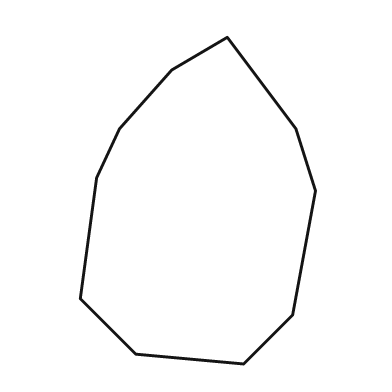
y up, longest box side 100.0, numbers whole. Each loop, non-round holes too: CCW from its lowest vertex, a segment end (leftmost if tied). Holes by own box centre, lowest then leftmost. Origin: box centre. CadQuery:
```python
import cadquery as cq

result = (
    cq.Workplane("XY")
    .moveTo(14.0, -50.0)
    .lineTo(29.0, -35.0)
    .lineTo(36.0, 3.0)
    .lineTo(30.0, 22.0)
    .lineTo(9.0, 50.0)
    .lineTo(-8.0, 40.0)
    .lineTo(-24.0, 22.0)
    .lineTo(-31.0, 7.0)
    .lineTo(-36.0, -30.0)
    .lineTo(-19.0, -47.0)
    .close()
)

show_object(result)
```